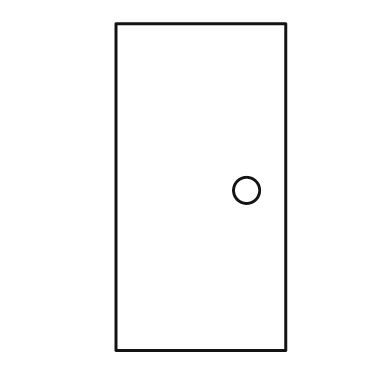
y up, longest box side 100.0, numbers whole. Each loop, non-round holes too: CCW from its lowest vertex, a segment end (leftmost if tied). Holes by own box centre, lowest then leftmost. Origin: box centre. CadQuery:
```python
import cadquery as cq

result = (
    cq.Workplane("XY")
    .moveTo(-26.0, -50.0)
    .lineTo(26.0, -50.0)
    .lineTo(26.0, 50.0)
    .lineTo(-26.0, 50.0)
    .close()
    .moveTo(14.0, -1.0)
    .circle(4.0)
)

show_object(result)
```